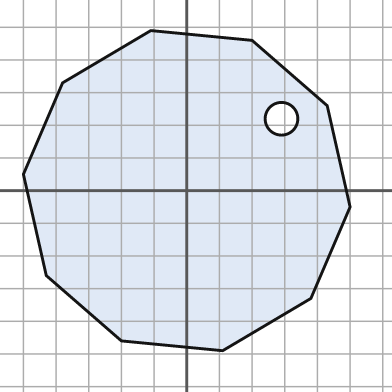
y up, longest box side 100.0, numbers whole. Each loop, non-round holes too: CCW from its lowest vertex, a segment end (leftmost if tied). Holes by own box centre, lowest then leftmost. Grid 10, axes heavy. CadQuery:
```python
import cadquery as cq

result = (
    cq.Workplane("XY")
    .moveTo(11.0, -49.0)
    .lineTo(38.0, -33.0)
    .lineTo(50.0, -5.0)
    .lineTo(43.0, 26.0)
    .lineTo(20.0, 46.0)
    .lineTo(-11.0, 49.0)
    .lineTo(-38.0, 33.0)
    .lineTo(-50.0, 5.0)
    .lineTo(-43.0, -26.0)
    .lineTo(-20.0, -46.0)
    .close()
    .moveTo(29.0, 22.0)
    .circle(5.0)
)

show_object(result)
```